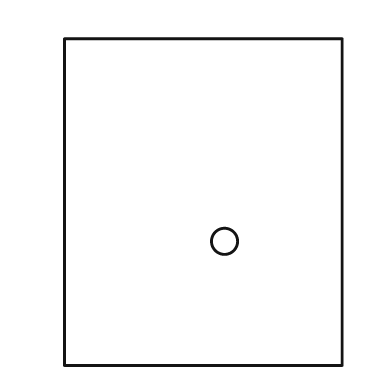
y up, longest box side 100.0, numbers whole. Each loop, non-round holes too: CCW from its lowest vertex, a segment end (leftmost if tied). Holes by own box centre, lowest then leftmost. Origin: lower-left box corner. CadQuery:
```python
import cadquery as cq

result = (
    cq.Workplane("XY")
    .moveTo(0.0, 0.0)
    .lineTo(85.0, 0.0)
    .lineTo(85.0, 100.0)
    .lineTo(0.0, 100.0)
    .close()
    .moveTo(49.0, 38.0)
    .circle(4.0)
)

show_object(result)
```